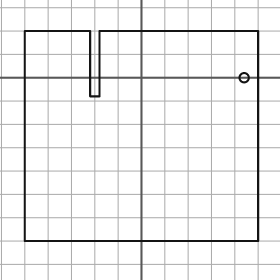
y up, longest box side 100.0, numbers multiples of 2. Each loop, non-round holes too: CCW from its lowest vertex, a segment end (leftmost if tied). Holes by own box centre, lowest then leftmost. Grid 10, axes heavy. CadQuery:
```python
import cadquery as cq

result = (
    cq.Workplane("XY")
    .moveTo(-50.0, -70.0)
    .lineTo(50.0, -70.0)
    .lineTo(50.0, 20.0)
    .lineTo(-18.0, 20.0)
    .lineTo(-18.0, -8.0)
    .lineTo(-22.0, -8.0)
    .lineTo(-22.0, 20.0)
    .lineTo(-50.0, 20.0)
    .close()
    .moveTo(44.0, 0.0)
    .circle(2.0)
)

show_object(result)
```